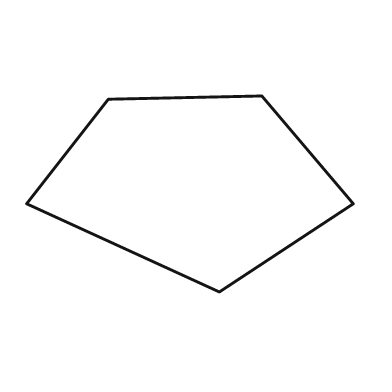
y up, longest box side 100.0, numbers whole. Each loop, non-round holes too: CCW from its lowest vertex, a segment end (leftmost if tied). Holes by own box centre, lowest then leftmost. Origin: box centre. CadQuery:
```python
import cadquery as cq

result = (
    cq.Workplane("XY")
    .moveTo(9.0, -30.0)
    .lineTo(50.0, -3.0)
    .lineTo(22.0, 30.0)
    .lineTo(-25.0, 29.0)
    .lineTo(-50.0, -3.0)
    .close()
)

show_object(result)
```